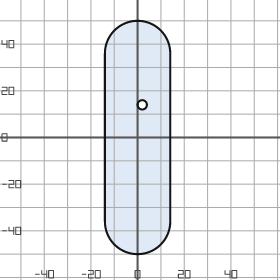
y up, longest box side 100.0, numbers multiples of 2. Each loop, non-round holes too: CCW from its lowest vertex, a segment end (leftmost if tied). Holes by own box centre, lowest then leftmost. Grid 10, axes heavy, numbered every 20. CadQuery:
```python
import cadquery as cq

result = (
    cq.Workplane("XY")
    .moveTo(-14.0, -36.0)
    .threePointArc((0.0, -50.0), (14.0, -36.0))
    .lineTo(14.0, 36.0)
    .threePointArc((0.0, 50.0), (-14.0, 36.0))
    .close()
    .moveTo(2.0, 14.0)
    .circle(2.0)
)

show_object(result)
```